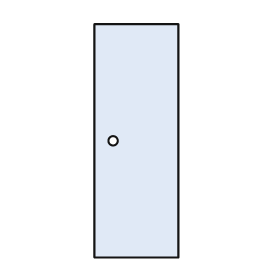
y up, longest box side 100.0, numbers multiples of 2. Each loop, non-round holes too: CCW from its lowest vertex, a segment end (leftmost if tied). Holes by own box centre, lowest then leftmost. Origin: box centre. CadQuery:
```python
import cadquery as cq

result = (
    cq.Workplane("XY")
    .moveTo(-18.0, -50.0)
    .lineTo(18.0, -50.0)
    .lineTo(18.0, 50.0)
    .lineTo(-18.0, 50.0)
    .close()
    .moveTo(-10.0, 0.0)
    .circle(2.0)
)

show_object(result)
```